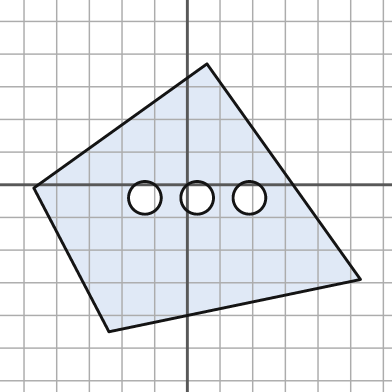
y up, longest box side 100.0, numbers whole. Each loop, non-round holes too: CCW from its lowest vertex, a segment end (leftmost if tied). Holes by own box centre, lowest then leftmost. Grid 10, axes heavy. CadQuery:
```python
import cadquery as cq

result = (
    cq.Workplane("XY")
    .moveTo(-24.0, -45.0)
    .lineTo(53.0, -29.0)
    .lineTo(6.0, 37.0)
    .lineTo(-47.0, -1.0)
    .close()
    .moveTo(-13.0, -4.0)
    .circle(5.0)
    .moveTo(3.0, -4.0)
    .circle(5.0)
    .moveTo(19.0, -4.0)
    .circle(5.0)
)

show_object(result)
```